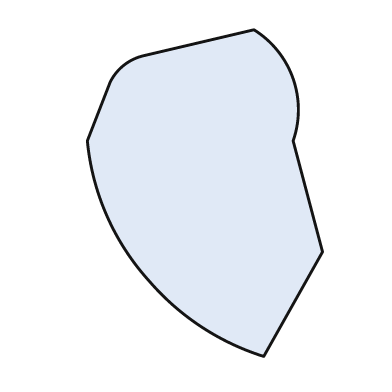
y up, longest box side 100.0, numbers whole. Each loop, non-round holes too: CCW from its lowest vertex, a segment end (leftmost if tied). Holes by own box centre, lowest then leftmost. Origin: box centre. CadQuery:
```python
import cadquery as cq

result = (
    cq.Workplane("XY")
    .moveTo(18.0, -50.0)
    .lineTo(36.0, -18.0)
    .lineTo(27.0, 16.0)
    .threePointArc((27.0, 35.0), (15.0, 50.0))
    .lineTo(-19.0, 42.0)
    .threePointArc((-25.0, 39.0), (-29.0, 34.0))
    .lineTo(-36.0, 16.0)
    .threePointArc((-30.0, -7.0), (-17.0, -27.0))
    .threePointArc((-1.0, -41.0), (18.0, -50.0))
    .close()
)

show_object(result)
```